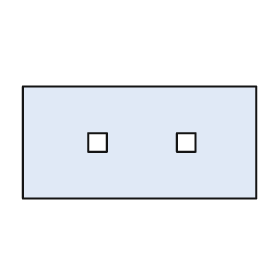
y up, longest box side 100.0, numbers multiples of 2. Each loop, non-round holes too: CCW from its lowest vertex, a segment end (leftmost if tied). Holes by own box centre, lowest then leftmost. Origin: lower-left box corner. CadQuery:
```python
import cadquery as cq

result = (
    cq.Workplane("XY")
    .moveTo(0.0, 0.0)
    .lineTo(100.0, 0.0)
    .lineTo(100.0, 48.0)
    .lineTo(0.0, 48.0)
    .close()
    .moveTo(28.0, 20.0)
    .lineTo(36.0, 20.0)
    .lineTo(36.0, 28.0)
    .lineTo(28.0, 28.0)
    .close()
    .moveTo(66.0, 20.0)
    .lineTo(74.0, 20.0)
    .lineTo(74.0, 28.0)
    .lineTo(66.0, 28.0)
    .close()
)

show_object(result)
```